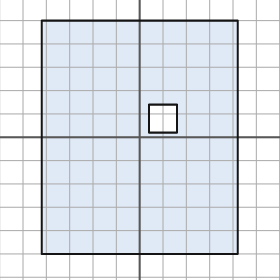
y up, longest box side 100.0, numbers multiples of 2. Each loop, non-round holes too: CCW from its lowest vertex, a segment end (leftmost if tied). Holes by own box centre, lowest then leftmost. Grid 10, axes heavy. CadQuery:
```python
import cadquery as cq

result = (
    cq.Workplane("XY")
    .moveTo(-42.0, -50.0)
    .lineTo(42.0, -50.0)
    .lineTo(42.0, 50.0)
    .lineTo(-42.0, 50.0)
    .close()
    .moveTo(4.0, 2.0)
    .lineTo(16.0, 2.0)
    .lineTo(16.0, 14.0)
    .lineTo(4.0, 14.0)
    .close()
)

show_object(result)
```